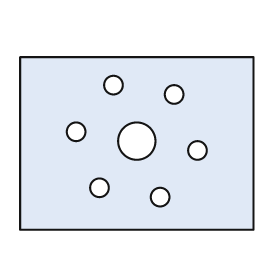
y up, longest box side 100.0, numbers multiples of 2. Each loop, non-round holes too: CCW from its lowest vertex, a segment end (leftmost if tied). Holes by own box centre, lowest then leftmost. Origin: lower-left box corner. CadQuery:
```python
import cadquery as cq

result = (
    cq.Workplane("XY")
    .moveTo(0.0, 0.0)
    .lineTo(100.0, 0.0)
    .lineTo(100.0, 74.0)
    .lineTo(0.0, 74.0)
    .close()
    .moveTo(60.0, 14.0)
    .circle(4.0)
    .moveTo(34.0, 18.0)
    .circle(4.0)
    .moveTo(76.0, 34.0)
    .circle(4.0)
    .moveTo(50.0, 38.0)
    .circle(8.0)
    .moveTo(24.0, 42.0)
    .circle(4.0)
    .moveTo(66.0, 58.0)
    .circle(4.0)
    .moveTo(40.0, 62.0)
    .circle(4.0)
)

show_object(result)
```